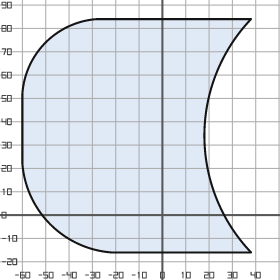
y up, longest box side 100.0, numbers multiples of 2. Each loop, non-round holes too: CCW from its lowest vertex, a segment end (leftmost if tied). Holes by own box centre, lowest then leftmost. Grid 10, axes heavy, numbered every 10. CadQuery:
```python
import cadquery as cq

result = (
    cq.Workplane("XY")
    .moveTo(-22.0, -16.0)
    .lineTo(38.0, -16.0)
    .threePointArc((18.0, 34.0), (38.0, 84.0))
    .lineTo(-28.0, 84.0)
    .threePointArc((-50.0, 74.0), (-60.0, 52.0))
    .lineTo(-60.0, 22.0)
    .threePointArc((-48.0, -4.0), (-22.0, -16.0))
    .close()
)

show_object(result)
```